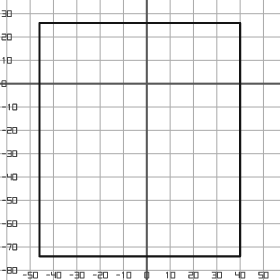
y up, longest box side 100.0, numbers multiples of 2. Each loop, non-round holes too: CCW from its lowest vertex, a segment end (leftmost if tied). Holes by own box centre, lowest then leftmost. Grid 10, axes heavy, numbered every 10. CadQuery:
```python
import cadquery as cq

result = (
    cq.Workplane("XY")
    .moveTo(-46.0, -74.0)
    .lineTo(40.0, -74.0)
    .lineTo(40.0, 26.0)
    .lineTo(-46.0, 26.0)
    .close()
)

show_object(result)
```